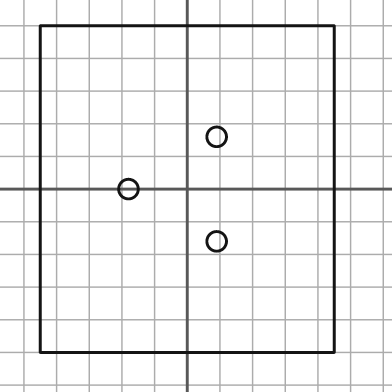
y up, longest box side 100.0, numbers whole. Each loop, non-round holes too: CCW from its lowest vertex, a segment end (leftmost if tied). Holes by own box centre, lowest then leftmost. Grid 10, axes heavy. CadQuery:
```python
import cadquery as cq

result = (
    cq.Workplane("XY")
    .moveTo(-45.0, -50.0)
    .lineTo(45.0, -50.0)
    .lineTo(45.0, 50.0)
    .lineTo(-45.0, 50.0)
    .close()
    .moveTo(9.0, -16.0)
    .circle(3.0)
    .moveTo(-18.0, 0.0)
    .circle(3.0)
    .moveTo(9.0, 16.0)
    .circle(3.0)
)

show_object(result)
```